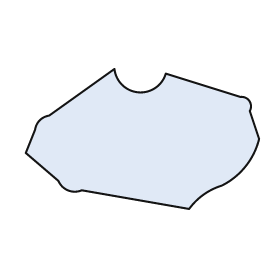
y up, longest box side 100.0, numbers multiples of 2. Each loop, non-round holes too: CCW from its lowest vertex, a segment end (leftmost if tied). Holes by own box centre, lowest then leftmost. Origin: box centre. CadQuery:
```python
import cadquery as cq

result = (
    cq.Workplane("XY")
    .moveTo(20.0, -30.0)
    .threePointArc((26.0, -24.0), (34.0, -20.0))
    .threePointArc((44.0, -12.0), (50.0, 0.0))
    .lineTo(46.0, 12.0)
    .threePointArc((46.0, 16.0), (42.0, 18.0))
    .lineTo(10.0, 28.0)
    .threePointArc((-2.0, 20.0), (-12.0, 30.0))
    .lineTo(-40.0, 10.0)
    .threePointArc((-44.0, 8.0), (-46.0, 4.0))
    .lineTo(-50.0, -6.0)
    .lineTo(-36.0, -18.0)
    .threePointArc((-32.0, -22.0), (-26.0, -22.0))
    .close()
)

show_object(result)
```